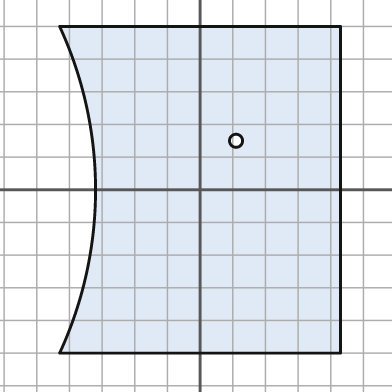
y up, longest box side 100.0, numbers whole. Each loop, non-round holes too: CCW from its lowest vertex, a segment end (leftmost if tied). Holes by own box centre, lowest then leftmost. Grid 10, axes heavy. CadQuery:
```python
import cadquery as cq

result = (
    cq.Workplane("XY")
    .moveTo(-43.0, -50.0)
    .lineTo(43.0, -50.0)
    .lineTo(43.0, 50.0)
    .lineTo(-43.0, 50.0)
    .threePointArc((-32.0, 0.0), (-43.0, -50.0))
    .close()
    .moveTo(11.0, 15.0)
    .circle(2.0)
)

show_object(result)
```